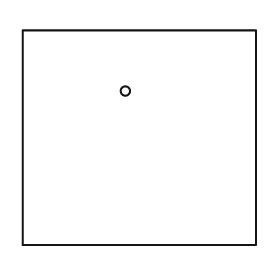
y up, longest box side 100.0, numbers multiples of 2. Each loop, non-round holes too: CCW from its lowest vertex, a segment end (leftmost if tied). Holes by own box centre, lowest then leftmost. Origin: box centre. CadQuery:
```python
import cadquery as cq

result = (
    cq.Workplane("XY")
    .moveTo(-50.0, -46.0)
    .lineTo(50.0, -46.0)
    .lineTo(50.0, 46.0)
    .lineTo(-50.0, 46.0)
    .close()
    .moveTo(-6.0, 20.0)
    .circle(2.0)
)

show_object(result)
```